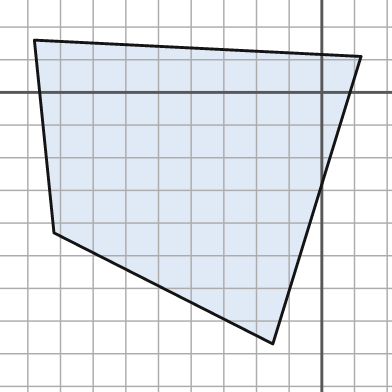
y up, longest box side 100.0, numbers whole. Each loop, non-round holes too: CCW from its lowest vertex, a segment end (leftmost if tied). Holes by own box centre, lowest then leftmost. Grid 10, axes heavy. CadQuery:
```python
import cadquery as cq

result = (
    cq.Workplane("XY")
    .moveTo(-15.0, -77.0)
    .lineTo(12.0, 11.0)
    .lineTo(-88.0, 16.0)
    .lineTo(-82.0, -43.0)
    .close()
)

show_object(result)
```